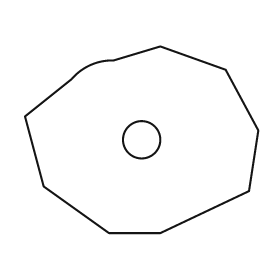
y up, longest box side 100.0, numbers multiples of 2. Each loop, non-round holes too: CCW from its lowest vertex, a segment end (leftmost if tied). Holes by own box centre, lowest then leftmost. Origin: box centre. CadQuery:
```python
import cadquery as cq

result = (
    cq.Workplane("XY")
    .moveTo(-14.0, -40.0)
    .lineTo(8.0, -40.0)
    .lineTo(46.0, -22.0)
    .lineTo(50.0, 4.0)
    .lineTo(36.0, 30.0)
    .lineTo(8.0, 40.0)
    .lineTo(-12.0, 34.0)
    .threePointArc((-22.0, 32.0), (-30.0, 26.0))
    .lineTo(-50.0, 10.0)
    .lineTo(-42.0, -20.0)
    .close()
    .moveTo(0.0, 0.0)
    .circle(8.0)
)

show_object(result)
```